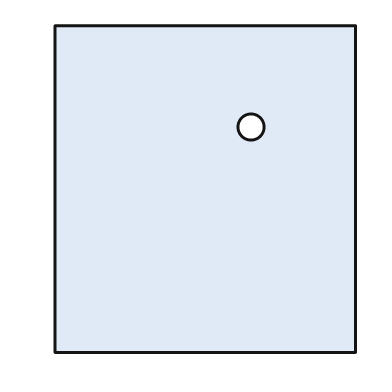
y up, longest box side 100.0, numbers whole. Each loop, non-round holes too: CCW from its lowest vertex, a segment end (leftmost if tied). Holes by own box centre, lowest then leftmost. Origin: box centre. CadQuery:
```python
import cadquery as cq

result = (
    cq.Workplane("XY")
    .moveTo(-46.0, -50.0)
    .lineTo(46.0, -50.0)
    .lineTo(46.0, 50.0)
    .lineTo(-46.0, 50.0)
    .close()
    .moveTo(14.0, 19.0)
    .circle(4.0)
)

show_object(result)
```